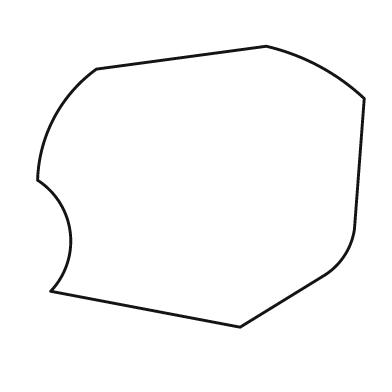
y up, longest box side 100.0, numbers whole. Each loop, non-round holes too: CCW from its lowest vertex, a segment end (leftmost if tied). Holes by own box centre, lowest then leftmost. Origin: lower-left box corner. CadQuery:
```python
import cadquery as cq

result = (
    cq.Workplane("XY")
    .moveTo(62.0, 0.0)
    .lineTo(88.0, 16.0)
    .threePointArc((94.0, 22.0), (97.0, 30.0))
    .lineTo(100.0, 70.0)
    .threePointArc((86.0, 80.0), (70.0, 86.0))
    .lineTo(18.0, 79.0)
    .threePointArc((5.0, 64.0), (0.0, 45.0))
    .threePointArc((10.0, 29.0), (4.0, 11.0))
    .close()
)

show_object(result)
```